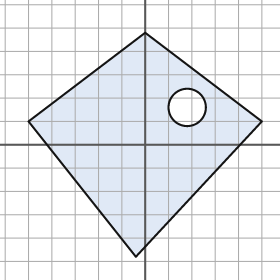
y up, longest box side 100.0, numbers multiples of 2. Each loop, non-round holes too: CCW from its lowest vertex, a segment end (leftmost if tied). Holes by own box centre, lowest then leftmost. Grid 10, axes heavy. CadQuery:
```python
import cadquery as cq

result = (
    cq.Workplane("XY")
    .moveTo(-4.0, -48.0)
    .lineTo(50.0, 10.0)
    .lineTo(0.0, 48.0)
    .lineTo(-50.0, 10.0)
    .close()
    .moveTo(18.0, 16.0)
    .circle(8.0)
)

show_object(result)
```